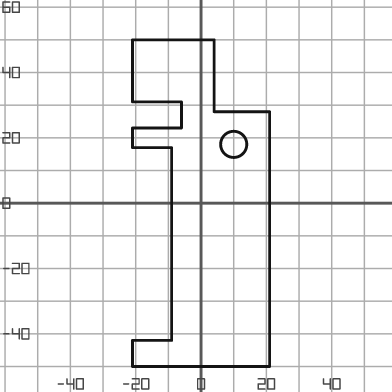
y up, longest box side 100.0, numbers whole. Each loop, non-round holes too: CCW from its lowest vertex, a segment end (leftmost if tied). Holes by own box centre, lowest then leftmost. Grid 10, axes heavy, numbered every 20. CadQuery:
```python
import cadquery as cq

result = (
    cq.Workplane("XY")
    .moveTo(-21.0, -50.0)
    .lineTo(21.0, -50.0)
    .lineTo(21.0, 28.0)
    .lineTo(4.0, 28.0)
    .lineTo(4.0, 50.0)
    .lineTo(-21.0, 50.0)
    .lineTo(-21.0, 31.0)
    .lineTo(-6.0, 31.0)
    .lineTo(-6.0, 23.0)
    .lineTo(-21.0, 23.0)
    .lineTo(-21.0, 17.0)
    .lineTo(-9.0, 17.0)
    .lineTo(-9.0, -42.0)
    .lineTo(-21.0, -42.0)
    .close()
    .moveTo(10.0, 18.0)
    .circle(4.0)
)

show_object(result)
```